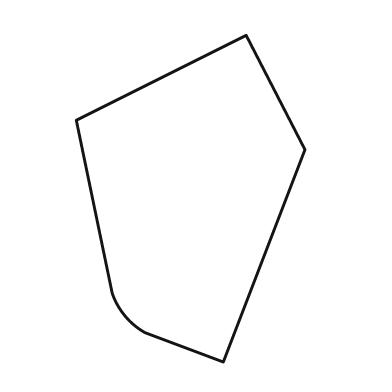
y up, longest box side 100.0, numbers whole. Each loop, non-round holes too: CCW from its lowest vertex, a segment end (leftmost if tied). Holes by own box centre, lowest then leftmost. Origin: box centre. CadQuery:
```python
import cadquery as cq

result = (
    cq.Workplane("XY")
    .moveTo(10.0, -50.0)
    .lineTo(35.0, 15.0)
    .lineTo(17.0, 50.0)
    .lineTo(-35.0, 24.0)
    .lineTo(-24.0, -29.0)
    .threePointArc((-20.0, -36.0), (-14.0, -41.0))
    .close()
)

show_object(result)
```